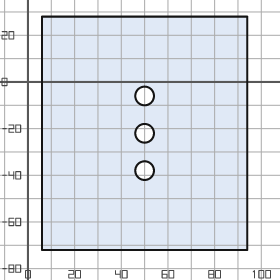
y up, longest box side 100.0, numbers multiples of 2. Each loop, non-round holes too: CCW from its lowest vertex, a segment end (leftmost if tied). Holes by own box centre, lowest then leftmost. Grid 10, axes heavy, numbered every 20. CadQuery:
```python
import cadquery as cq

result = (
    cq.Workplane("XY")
    .moveTo(6.0, -72.0)
    .lineTo(94.0, -72.0)
    .lineTo(94.0, 28.0)
    .lineTo(6.0, 28.0)
    .close()
    .moveTo(50.0, -38.0)
    .circle(4.0)
    .moveTo(50.0, -22.0)
    .circle(4.0)
    .moveTo(50.0, -6.0)
    .circle(4.0)
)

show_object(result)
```